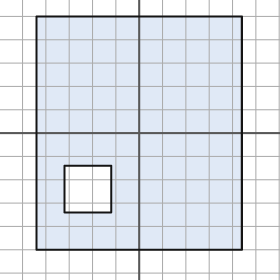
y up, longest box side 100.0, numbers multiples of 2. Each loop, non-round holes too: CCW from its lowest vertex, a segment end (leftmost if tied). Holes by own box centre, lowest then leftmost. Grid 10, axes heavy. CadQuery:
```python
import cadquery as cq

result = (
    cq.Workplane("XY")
    .moveTo(-44.0, -50.0)
    .lineTo(44.0, -50.0)
    .lineTo(44.0, 50.0)
    .lineTo(-44.0, 50.0)
    .close()
    .moveTo(-32.0, -34.0)
    .lineTo(-12.0, -34.0)
    .lineTo(-12.0, -14.0)
    .lineTo(-32.0, -14.0)
    .close()
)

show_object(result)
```